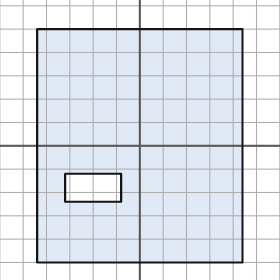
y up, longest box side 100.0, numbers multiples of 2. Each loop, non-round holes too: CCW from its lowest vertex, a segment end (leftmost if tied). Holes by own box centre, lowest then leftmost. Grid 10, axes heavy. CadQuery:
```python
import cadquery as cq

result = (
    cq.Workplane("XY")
    .moveTo(-44.0, -50.0)
    .lineTo(44.0, -50.0)
    .lineTo(44.0, 50.0)
    .lineTo(-44.0, 50.0)
    .close()
    .moveTo(-32.0, -24.0)
    .lineTo(-8.0, -24.0)
    .lineTo(-8.0, -12.0)
    .lineTo(-32.0, -12.0)
    .close()
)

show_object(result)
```